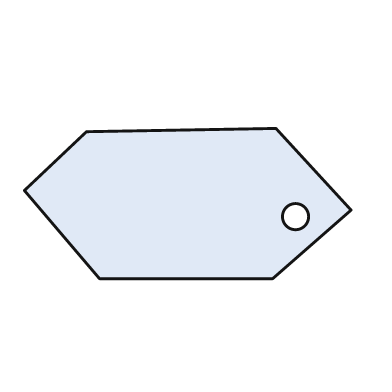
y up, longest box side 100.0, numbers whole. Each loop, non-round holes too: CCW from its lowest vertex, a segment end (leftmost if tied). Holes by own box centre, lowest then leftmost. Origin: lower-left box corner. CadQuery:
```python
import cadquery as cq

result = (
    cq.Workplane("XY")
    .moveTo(23.0, 0.0)
    .lineTo(76.0, 0.0)
    .lineTo(100.0, 21.0)
    .lineTo(77.0, 46.0)
    .lineTo(19.0, 45.0)
    .lineTo(0.0, 27.0)
    .close()
    .moveTo(83.0, 19.0)
    .circle(4.0)
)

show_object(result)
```